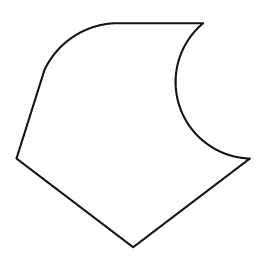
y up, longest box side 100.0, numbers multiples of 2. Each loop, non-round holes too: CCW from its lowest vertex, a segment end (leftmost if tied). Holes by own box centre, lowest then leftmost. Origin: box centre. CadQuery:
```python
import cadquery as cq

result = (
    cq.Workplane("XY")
    .moveTo(0.0, -48.0)
    .lineTo(50.0, -10.0)
    .threePointArc((20.0, 12.0), (30.0, 48.0))
    .lineTo(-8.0, 48.0)
    .threePointArc((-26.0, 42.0), (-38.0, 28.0))
    .lineTo(-50.0, -10.0)
    .close()
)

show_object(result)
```